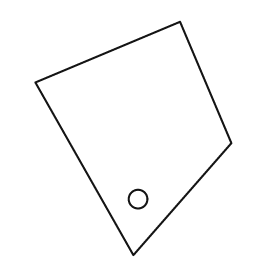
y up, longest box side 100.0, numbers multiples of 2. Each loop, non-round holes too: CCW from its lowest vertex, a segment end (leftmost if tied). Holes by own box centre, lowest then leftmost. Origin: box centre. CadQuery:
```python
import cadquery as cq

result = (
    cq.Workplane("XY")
    .moveTo(0.0, -50.0)
    .lineTo(42.0, -2.0)
    .lineTo(20.0, 50.0)
    .lineTo(-42.0, 24.0)
    .close()
    .moveTo(2.0, -26.0)
    .circle(4.0)
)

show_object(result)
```